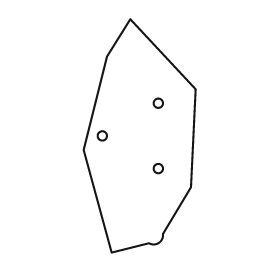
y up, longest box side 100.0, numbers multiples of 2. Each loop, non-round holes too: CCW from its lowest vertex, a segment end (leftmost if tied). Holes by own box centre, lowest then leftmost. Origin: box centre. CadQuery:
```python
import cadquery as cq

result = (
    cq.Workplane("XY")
    .moveTo(-12.0, -50.0)
    .lineTo(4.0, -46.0)
    .threePointArc((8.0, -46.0), (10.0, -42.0))
    .lineTo(22.0, -22.0)
    .lineTo(24.0, 20.0)
    .lineTo(-4.0, 50.0)
    .lineTo(-14.0, 34.0)
    .lineTo(-24.0, -6.0)
    .close()
    .moveTo(8.0, -14.0)
    .circle(2.0)
    .moveTo(-16.0, 0.0)
    .circle(2.0)
    .moveTo(8.0, 14.0)
    .circle(2.0)
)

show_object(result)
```